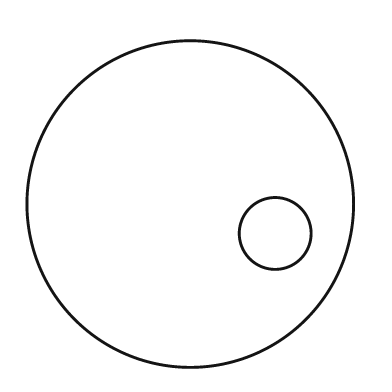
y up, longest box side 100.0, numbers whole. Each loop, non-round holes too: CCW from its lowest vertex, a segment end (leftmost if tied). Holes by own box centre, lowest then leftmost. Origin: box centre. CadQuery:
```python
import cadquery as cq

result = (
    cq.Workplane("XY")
    .moveTo(0.0, 0.0)
    .circle(50.0)
    .moveTo(26.0, -9.0)
    .circle(11.0)
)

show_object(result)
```